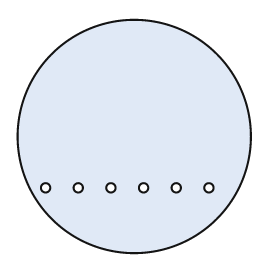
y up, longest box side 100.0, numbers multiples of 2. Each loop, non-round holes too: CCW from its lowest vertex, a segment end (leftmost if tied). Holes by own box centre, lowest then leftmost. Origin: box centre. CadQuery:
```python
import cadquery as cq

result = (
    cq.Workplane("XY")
    .moveTo(0.0, 0.0)
    .circle(50.0)
    .moveTo(-38.0, -22.0)
    .circle(2.0)
    .moveTo(-24.0, -22.0)
    .circle(2.0)
    .moveTo(-10.0, -22.0)
    .circle(2.0)
    .moveTo(4.0, -22.0)
    .circle(2.0)
    .moveTo(18.0, -22.0)
    .circle(2.0)
    .moveTo(32.0, -22.0)
    .circle(2.0)
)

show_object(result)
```